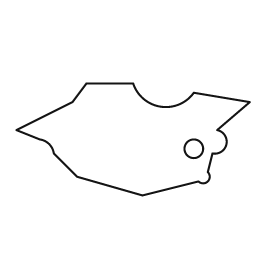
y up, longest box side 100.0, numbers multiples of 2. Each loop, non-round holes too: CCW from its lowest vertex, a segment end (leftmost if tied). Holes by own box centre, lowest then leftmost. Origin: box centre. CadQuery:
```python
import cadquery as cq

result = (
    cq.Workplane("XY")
    .moveTo(4.0, -24.0)
    .lineTo(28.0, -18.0)
    .threePointArc((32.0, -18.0), (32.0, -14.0))
    .lineTo(34.0, -6.0)
    .threePointArc((40.0, -2.0), (36.0, 4.0))
    .lineTo(50.0, 16.0)
    .lineTo(26.0, 20.0)
    .threePointArc((12.0, 14.0), (0.0, 24.0))
    .lineTo(-20.0, 24.0)
    .lineTo(-26.0, 16.0)
    .lineTo(-50.0, 4.0)
    .lineTo(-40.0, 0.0)
    .threePointArc((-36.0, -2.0), (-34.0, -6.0))
    .lineTo(-24.0, -16.0)
    .close()
    .moveTo(26.0, -4.0)
    .circle(4.0)
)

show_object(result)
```